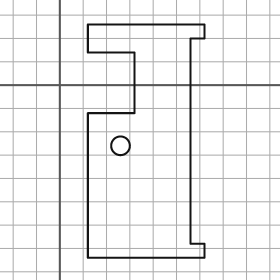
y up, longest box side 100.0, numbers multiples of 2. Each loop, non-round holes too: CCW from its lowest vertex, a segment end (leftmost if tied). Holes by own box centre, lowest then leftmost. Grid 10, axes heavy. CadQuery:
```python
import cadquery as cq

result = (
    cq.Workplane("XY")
    .moveTo(12.0, -74.0)
    .lineTo(62.0, -74.0)
    .lineTo(62.0, -68.0)
    .lineTo(56.0, -68.0)
    .lineTo(56.0, 20.0)
    .lineTo(62.0, 20.0)
    .lineTo(62.0, 26.0)
    .lineTo(12.0, 26.0)
    .lineTo(12.0, 14.0)
    .lineTo(32.0, 14.0)
    .lineTo(32.0, -12.0)
    .lineTo(12.0, -12.0)
    .close()
    .moveTo(26.0, -26.0)
    .circle(4.0)
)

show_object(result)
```